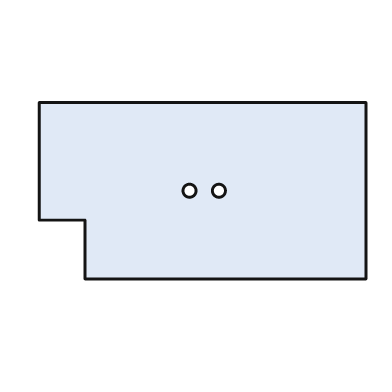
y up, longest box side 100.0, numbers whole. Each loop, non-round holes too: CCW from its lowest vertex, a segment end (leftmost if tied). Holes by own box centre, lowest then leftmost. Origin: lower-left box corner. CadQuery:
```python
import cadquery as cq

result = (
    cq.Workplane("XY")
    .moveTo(14.0, 0.0)
    .lineTo(100.0, 0.0)
    .lineTo(100.0, 54.0)
    .lineTo(0.0, 54.0)
    .lineTo(0.0, 18.0)
    .lineTo(14.0, 18.0)
    .close()
    .moveTo(46.0, 27.0)
    .circle(2.0)
    .moveTo(55.0, 27.0)
    .circle(2.0)
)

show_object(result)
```